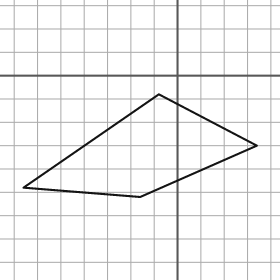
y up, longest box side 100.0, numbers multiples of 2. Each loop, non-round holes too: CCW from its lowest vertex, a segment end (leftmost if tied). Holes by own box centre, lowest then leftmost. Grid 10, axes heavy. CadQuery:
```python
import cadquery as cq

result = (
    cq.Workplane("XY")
    .moveTo(-16.0, -52.0)
    .lineTo(34.0, -30.0)
    .lineTo(-8.0, -8.0)
    .lineTo(-66.0, -48.0)
    .close()
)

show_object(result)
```